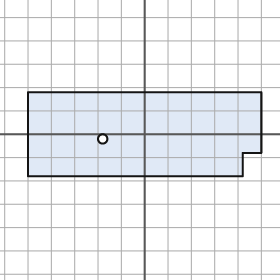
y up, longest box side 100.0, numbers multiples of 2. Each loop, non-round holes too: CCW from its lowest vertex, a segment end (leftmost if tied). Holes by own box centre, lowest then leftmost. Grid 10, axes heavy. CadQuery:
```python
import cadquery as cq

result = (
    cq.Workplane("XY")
    .moveTo(-50.0, -18.0)
    .lineTo(42.0, -18.0)
    .lineTo(42.0, -8.0)
    .lineTo(50.0, -8.0)
    .lineTo(50.0, 18.0)
    .lineTo(-50.0, 18.0)
    .close()
    .moveTo(-18.0, -2.0)
    .circle(2.0)
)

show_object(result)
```